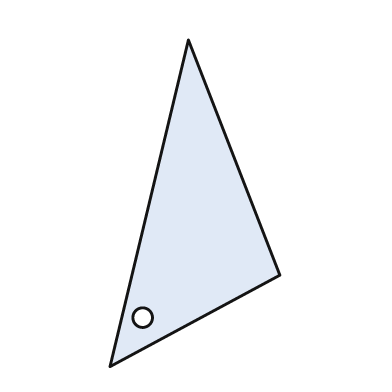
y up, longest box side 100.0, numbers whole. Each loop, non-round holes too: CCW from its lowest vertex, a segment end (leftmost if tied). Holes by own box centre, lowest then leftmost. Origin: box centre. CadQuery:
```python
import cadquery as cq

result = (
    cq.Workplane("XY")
    .moveTo(-26.0, -50.0)
    .lineTo(26.0, -22.0)
    .lineTo(-2.0, 50.0)
    .close()
    .moveTo(-16.0, -35.0)
    .circle(3.0)
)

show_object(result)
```